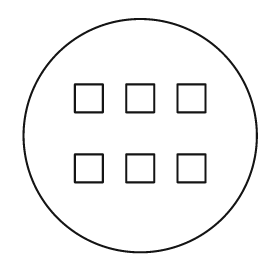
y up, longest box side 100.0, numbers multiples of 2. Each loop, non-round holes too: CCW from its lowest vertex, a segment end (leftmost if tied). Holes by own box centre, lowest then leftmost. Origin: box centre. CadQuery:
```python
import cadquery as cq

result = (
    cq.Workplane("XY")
    .moveTo(0.0, 0.0)
    .circle(50.0)
    .moveTo(-28.0, -20.0)
    .lineTo(-16.0, -20.0)
    .lineTo(-16.0, -8.0)
    .lineTo(-28.0, -8.0)
    .close()
    .moveTo(-6.0, -20.0)
    .lineTo(6.0, -20.0)
    .lineTo(6.0, -8.0)
    .lineTo(-6.0, -8.0)
    .close()
    .moveTo(16.0, -20.0)
    .lineTo(28.0, -20.0)
    .lineTo(28.0, -8.0)
    .lineTo(16.0, -8.0)
    .close()
    .moveTo(-28.0, 10.0)
    .lineTo(-16.0, 10.0)
    .lineTo(-16.0, 22.0)
    .lineTo(-28.0, 22.0)
    .close()
    .moveTo(-6.0, 10.0)
    .lineTo(6.0, 10.0)
    .lineTo(6.0, 22.0)
    .lineTo(-6.0, 22.0)
    .close()
    .moveTo(16.0, 10.0)
    .lineTo(28.0, 10.0)
    .lineTo(28.0, 22.0)
    .lineTo(16.0, 22.0)
    .close()
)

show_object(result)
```